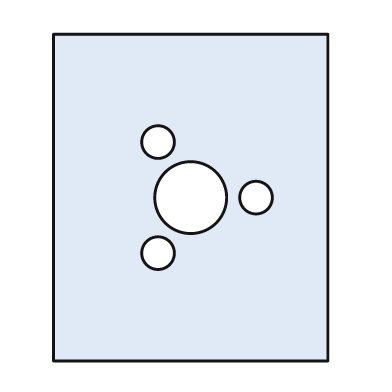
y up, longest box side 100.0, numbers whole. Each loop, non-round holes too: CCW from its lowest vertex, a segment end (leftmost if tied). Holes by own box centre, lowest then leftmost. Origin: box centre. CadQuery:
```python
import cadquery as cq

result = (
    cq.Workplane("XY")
    .moveTo(-42.0, -50.0)
    .lineTo(42.0, -50.0)
    .lineTo(42.0, 50.0)
    .lineTo(-42.0, 50.0)
    .close()
    .moveTo(-10.0, -17.0)
    .circle(5.0)
    .moveTo(0.0, 0.0)
    .circle(11.0)
    .moveTo(20.0, 0.0)
    .circle(5.0)
    .moveTo(-10.0, 17.0)
    .circle(5.0)
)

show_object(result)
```